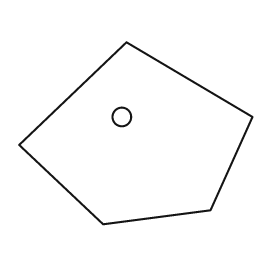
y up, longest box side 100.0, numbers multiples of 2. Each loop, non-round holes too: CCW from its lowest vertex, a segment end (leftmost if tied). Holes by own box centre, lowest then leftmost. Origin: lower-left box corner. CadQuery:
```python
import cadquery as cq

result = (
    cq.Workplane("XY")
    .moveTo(36.0, 0.0)
    .lineTo(82.0, 6.0)
    .lineTo(100.0, 46.0)
    .lineTo(46.0, 78.0)
    .lineTo(0.0, 34.0)
    .close()
    .moveTo(44.0, 46.0)
    .circle(4.0)
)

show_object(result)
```